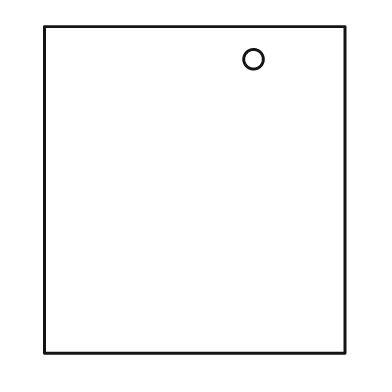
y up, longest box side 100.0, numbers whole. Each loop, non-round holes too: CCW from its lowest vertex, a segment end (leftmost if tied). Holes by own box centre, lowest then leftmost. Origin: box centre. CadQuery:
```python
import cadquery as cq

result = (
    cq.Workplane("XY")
    .moveTo(-46.0, -50.0)
    .lineTo(46.0, -50.0)
    .lineTo(46.0, 50.0)
    .lineTo(-46.0, 50.0)
    .close()
    .moveTo(18.0, 40.0)
    .circle(3.0)
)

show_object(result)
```